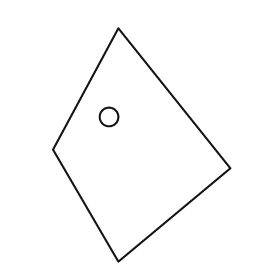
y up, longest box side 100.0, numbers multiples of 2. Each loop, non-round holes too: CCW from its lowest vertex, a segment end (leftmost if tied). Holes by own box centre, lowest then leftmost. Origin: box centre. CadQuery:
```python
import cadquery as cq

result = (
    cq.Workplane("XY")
    .moveTo(-10.0, -50.0)
    .lineTo(38.0, -10.0)
    .lineTo(-10.0, 50.0)
    .lineTo(-38.0, -2.0)
    .close()
    .moveTo(-14.0, 12.0)
    .circle(4.0)
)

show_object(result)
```